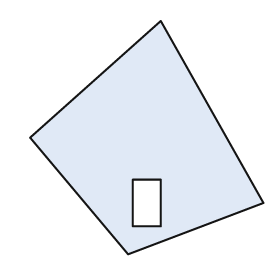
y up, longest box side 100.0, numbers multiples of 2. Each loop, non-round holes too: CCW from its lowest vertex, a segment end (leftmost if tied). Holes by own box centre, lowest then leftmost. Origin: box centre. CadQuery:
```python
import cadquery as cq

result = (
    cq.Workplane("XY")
    .moveTo(-8.0, -50.0)
    .lineTo(50.0, -28.0)
    .lineTo(6.0, 50.0)
    .lineTo(-50.0, 0.0)
    .close()
    .moveTo(-6.0, -38.0)
    .lineTo(6.0, -38.0)
    .lineTo(6.0, -18.0)
    .lineTo(-6.0, -18.0)
    .close()
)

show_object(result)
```